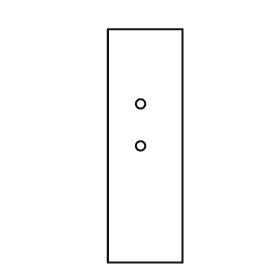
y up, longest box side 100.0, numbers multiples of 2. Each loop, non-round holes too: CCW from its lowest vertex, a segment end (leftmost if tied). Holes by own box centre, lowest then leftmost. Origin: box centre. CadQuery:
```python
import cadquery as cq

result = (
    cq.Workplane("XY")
    .moveTo(-16.0, -50.0)
    .lineTo(16.0, -50.0)
    .lineTo(16.0, 50.0)
    .lineTo(-16.0, 50.0)
    .close()
    .moveTo(-2.0, 0.0)
    .circle(2.0)
    .moveTo(-2.0, 18.0)
    .circle(2.0)
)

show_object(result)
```